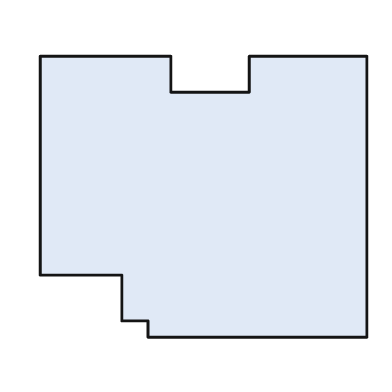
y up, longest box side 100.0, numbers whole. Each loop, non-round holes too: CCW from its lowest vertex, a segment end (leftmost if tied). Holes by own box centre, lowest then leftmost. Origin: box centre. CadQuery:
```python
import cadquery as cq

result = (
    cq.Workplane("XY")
    .moveTo(-17.0, -43.0)
    .lineTo(50.0, -43.0)
    .lineTo(50.0, 43.0)
    .lineTo(14.0, 43.0)
    .lineTo(14.0, 32.0)
    .lineTo(-10.0, 32.0)
    .lineTo(-10.0, 43.0)
    .lineTo(-50.0, 43.0)
    .lineTo(-50.0, -24.0)
    .lineTo(-25.0, -24.0)
    .lineTo(-25.0, -38.0)
    .lineTo(-17.0, -38.0)
    .close()
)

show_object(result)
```